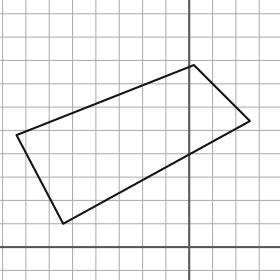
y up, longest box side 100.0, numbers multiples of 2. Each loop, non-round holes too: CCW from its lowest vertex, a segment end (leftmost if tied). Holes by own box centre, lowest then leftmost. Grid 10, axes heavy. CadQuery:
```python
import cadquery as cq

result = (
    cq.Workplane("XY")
    .moveTo(-54.0, 10.0)
    .lineTo(26.0, 54.0)
    .lineTo(2.0, 78.0)
    .lineTo(-74.0, 48.0)
    .close()
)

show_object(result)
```